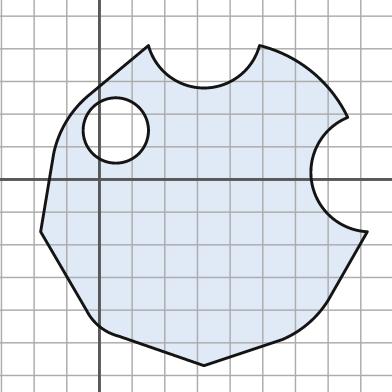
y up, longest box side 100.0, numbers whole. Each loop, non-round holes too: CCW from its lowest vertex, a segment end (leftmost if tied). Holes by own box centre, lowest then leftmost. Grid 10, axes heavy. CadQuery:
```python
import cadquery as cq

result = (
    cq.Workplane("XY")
    .moveTo(32.0, -57.0)
    .lineTo(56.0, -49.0)
    .threePointArc((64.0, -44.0), (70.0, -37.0))
    .lineTo(82.0, -16.0)
    .threePointArc((65.0, -1.0), (76.0, 19.0))
    .threePointArc((65.0, 33.0), (49.0, 41.0))
    .threePointArc((32.0, 28.0), (15.0, 41.0))
    .lineTo(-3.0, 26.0)
    .threePointArc((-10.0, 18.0), (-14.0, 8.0))
    .lineTo(-18.0, -16.0)
    .lineTo(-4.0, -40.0)
    .threePointArc((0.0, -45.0), (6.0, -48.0))
    .close()
    .moveTo(5.0, 15.0)
    .circle(10.0)
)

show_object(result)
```